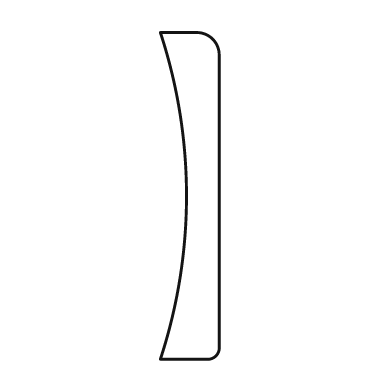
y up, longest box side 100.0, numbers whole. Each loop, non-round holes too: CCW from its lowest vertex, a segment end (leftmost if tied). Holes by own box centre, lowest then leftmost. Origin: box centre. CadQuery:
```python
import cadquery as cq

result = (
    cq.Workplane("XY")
    .moveTo(-9.0, -50.0)
    .lineTo(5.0, -50.0)
    .threePointArc((8.0, -49.0), (9.0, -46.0))
    .lineTo(9.0, 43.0)
    .threePointArc((7.0, 48.0), (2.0, 50.0))
    .lineTo(-9.0, 50.0)
    .threePointArc((-1.0, 0.0), (-9.0, -50.0))
    .close()
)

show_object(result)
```